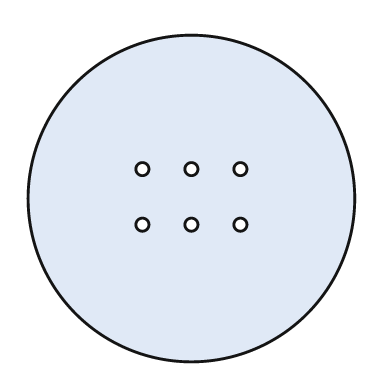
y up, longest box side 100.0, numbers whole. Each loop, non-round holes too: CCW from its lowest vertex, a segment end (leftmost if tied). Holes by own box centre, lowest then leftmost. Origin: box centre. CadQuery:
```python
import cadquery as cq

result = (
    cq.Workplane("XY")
    .moveTo(0.0, 0.0)
    .circle(50.0)
    .moveTo(-15.0, -8.0)
    .circle(2.0)
    .moveTo(0.0, -8.0)
    .circle(2.0)
    .moveTo(15.0, -8.0)
    .circle(2.0)
    .moveTo(-15.0, 9.0)
    .circle(2.0)
    .moveTo(0.0, 9.0)
    .circle(2.0)
    .moveTo(15.0, 9.0)
    .circle(2.0)
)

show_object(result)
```